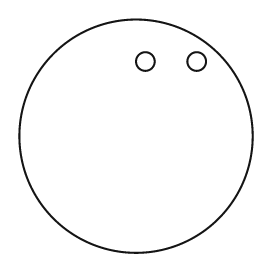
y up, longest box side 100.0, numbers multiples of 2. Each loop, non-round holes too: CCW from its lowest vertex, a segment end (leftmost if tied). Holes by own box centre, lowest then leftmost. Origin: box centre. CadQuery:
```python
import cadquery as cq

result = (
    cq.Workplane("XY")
    .moveTo(0.0, 0.0)
    .circle(50.0)
    .moveTo(4.0, 32.0)
    .circle(4.0)
    .moveTo(26.0, 32.0)
    .circle(4.0)
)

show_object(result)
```